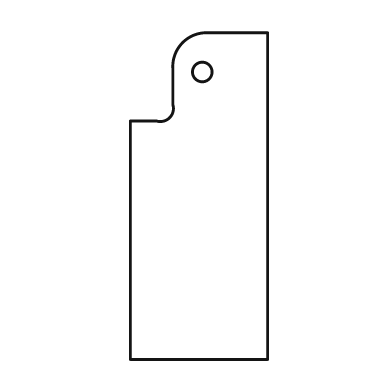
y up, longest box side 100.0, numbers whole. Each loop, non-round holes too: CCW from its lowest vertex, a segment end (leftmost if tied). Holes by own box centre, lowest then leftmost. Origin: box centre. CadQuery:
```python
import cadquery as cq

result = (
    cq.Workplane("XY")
    .moveTo(-21.0, -50.0)
    .lineTo(21.0, -50.0)
    .lineTo(21.0, 50.0)
    .lineTo(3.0, 50.0)
    .threePointArc((-5.0, 47.0), (-8.0, 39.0))
    .lineTo(-8.0, 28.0)
    .threePointArc((-9.0, 24.0), (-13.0, 23.0))
    .lineTo(-21.0, 23.0)
    .close()
    .moveTo(1.0, 38.0)
    .circle(3.0)
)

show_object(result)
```